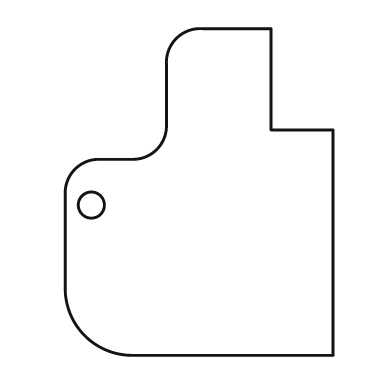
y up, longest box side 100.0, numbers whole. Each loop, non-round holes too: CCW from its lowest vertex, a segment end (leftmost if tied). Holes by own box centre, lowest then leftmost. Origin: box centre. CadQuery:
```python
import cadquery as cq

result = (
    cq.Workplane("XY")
    .moveTo(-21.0, -50.0)
    .lineTo(41.0, -50.0)
    .lineTo(41.0, 19.0)
    .lineTo(22.0, 19.0)
    .lineTo(22.0, 50.0)
    .lineTo(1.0, 50.0)
    .threePointArc((-7.0, 47.0), (-10.0, 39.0))
    .lineTo(-10.0, 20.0)
    .threePointArc((-13.0, 13.0), (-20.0, 10.0))
    .lineTo(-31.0, 10.0)
    .threePointArc((-38.0, 7.0), (-41.0, 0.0))
    .lineTo(-41.0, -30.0)
    .threePointArc((-35.0, -44.0), (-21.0, -50.0))
    .close()
    .moveTo(-33.0, -4.0)
    .circle(4.0)
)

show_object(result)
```